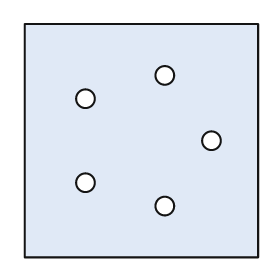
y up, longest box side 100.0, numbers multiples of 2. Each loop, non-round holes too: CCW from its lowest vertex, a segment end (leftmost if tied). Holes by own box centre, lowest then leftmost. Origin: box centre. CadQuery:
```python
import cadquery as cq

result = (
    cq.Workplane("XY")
    .moveTo(-50.0, -50.0)
    .lineTo(50.0, -50.0)
    .lineTo(50.0, 50.0)
    .lineTo(-50.0, 50.0)
    .close()
    .moveTo(10.0, -28.0)
    .circle(4.0)
    .moveTo(-24.0, -18.0)
    .circle(4.0)
    .moveTo(30.0, 0.0)
    .circle(4.0)
    .moveTo(-24.0, 18.0)
    .circle(4.0)
    .moveTo(10.0, 28.0)
    .circle(4.0)
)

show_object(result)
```